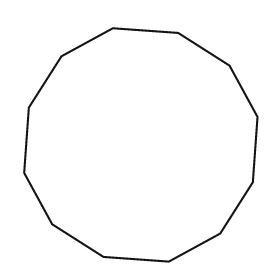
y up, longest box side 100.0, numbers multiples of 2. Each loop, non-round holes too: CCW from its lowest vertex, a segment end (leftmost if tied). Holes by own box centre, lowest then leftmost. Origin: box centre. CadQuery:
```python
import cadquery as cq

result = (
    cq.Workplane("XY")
    .moveTo(12.0, -50.0)
    .lineTo(34.0, -38.0)
    .lineTo(48.0, -16.0)
    .lineTo(50.0, 12.0)
    .lineTo(38.0, 34.0)
    .lineTo(16.0, 48.0)
    .lineTo(-12.0, 50.0)
    .lineTo(-34.0, 38.0)
    .lineTo(-48.0, 16.0)
    .lineTo(-50.0, -12.0)
    .lineTo(-38.0, -34.0)
    .lineTo(-16.0, -48.0)
    .close()
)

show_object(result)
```